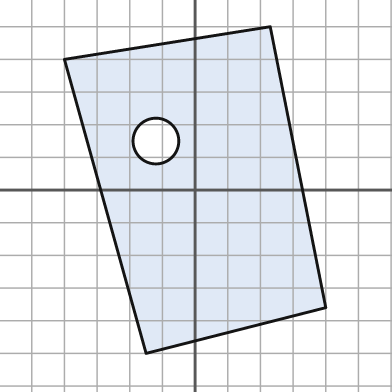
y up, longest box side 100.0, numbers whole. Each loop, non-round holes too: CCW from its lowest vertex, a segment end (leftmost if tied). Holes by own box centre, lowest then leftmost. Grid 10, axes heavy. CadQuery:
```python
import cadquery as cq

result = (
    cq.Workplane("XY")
    .moveTo(-15.0, -50.0)
    .lineTo(40.0, -36.0)
    .lineTo(23.0, 50.0)
    .lineTo(-40.0, 40.0)
    .close()
    .moveTo(-12.0, 15.0)
    .circle(7.0)
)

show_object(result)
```